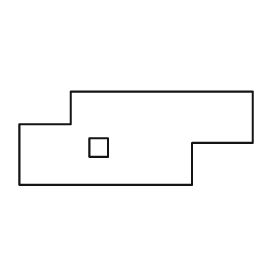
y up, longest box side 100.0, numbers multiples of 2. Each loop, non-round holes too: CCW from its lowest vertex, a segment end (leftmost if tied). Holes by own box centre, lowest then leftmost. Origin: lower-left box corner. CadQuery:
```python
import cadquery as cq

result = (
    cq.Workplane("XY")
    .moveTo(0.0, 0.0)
    .lineTo(74.0, 0.0)
    .lineTo(74.0, 18.0)
    .lineTo(100.0, 18.0)
    .lineTo(100.0, 40.0)
    .lineTo(22.0, 40.0)
    .lineTo(22.0, 26.0)
    .lineTo(0.0, 26.0)
    .close()
    .moveTo(30.0, 12.0)
    .lineTo(38.0, 12.0)
    .lineTo(38.0, 20.0)
    .lineTo(30.0, 20.0)
    .close()
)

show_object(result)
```